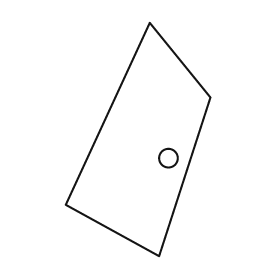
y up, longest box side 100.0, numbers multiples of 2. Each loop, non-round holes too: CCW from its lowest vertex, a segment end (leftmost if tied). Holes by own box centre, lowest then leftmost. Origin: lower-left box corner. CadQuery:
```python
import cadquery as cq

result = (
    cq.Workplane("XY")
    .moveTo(40.0, 0.0)
    .lineTo(62.0, 68.0)
    .lineTo(36.0, 100.0)
    .lineTo(0.0, 22.0)
    .close()
    .moveTo(44.0, 42.0)
    .circle(4.0)
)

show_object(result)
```